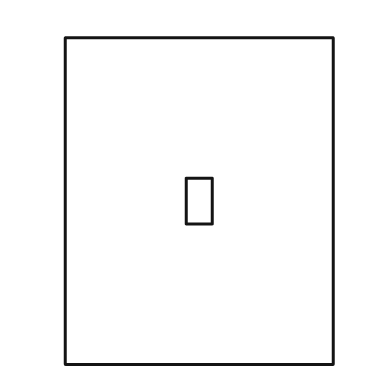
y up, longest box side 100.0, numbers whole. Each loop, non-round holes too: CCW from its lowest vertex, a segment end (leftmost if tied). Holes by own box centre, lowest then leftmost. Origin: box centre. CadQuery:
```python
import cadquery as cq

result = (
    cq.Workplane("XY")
    .moveTo(-41.0, -50.0)
    .lineTo(41.0, -50.0)
    .lineTo(41.0, 50.0)
    .lineTo(-41.0, 50.0)
    .close()
    .moveTo(-4.0, -7.0)
    .lineTo(4.0, -7.0)
    .lineTo(4.0, 7.0)
    .lineTo(-4.0, 7.0)
    .close()
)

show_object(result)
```